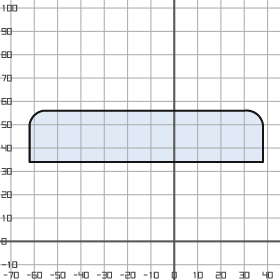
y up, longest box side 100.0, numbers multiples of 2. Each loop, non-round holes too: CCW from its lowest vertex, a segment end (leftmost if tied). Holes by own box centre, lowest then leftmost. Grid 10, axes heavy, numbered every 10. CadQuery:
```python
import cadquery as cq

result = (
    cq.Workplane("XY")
    .moveTo(-62.0, 34.0)
    .lineTo(38.0, 34.0)
    .lineTo(38.0, 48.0)
    .threePointArc((36.0, 54.0), (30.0, 56.0))
    .lineTo(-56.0, 56.0)
    .threePointArc((-60.0, 54.0), (-62.0, 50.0))
    .close()
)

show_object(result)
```